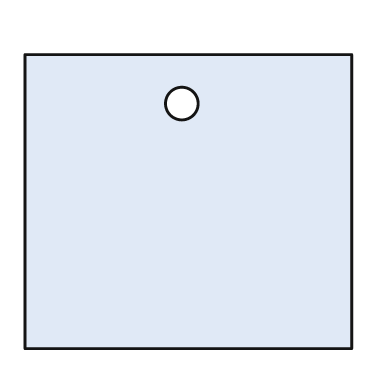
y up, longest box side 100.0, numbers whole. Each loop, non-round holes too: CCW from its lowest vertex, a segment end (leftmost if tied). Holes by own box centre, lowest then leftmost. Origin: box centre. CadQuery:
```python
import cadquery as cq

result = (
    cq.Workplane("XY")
    .moveTo(-50.0, -45.0)
    .lineTo(50.0, -45.0)
    .lineTo(50.0, 45.0)
    .lineTo(-50.0, 45.0)
    .close()
    .moveTo(-2.0, 30.0)
    .circle(5.0)
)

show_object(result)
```